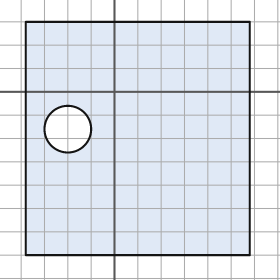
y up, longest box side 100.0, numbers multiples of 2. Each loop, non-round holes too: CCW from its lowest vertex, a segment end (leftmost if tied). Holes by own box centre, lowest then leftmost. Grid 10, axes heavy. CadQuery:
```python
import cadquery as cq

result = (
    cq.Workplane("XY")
    .moveTo(-38.0, -70.0)
    .lineTo(58.0, -70.0)
    .lineTo(58.0, 30.0)
    .lineTo(-38.0, 30.0)
    .close()
    .moveTo(-20.0, -16.0)
    .circle(10.0)
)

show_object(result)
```